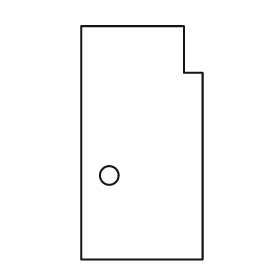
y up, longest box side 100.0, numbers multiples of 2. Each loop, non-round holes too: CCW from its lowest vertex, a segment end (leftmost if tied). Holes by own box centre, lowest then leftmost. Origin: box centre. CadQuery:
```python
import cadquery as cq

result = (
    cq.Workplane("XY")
    .moveTo(-26.0, -50.0)
    .lineTo(26.0, -50.0)
    .lineTo(26.0, 30.0)
    .lineTo(18.0, 30.0)
    .lineTo(18.0, 50.0)
    .lineTo(-26.0, 50.0)
    .close()
    .moveTo(-14.0, -14.0)
    .circle(4.0)
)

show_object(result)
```